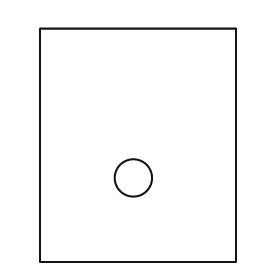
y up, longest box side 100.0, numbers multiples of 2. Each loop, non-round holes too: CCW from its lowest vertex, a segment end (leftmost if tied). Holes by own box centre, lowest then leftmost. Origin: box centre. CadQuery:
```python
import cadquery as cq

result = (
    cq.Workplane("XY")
    .moveTo(-42.0, -50.0)
    .lineTo(42.0, -50.0)
    .lineTo(42.0, 50.0)
    .lineTo(-42.0, 50.0)
    .close()
    .moveTo(-2.0, -14.0)
    .circle(8.0)
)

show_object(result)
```